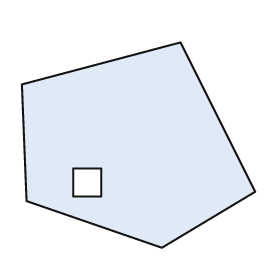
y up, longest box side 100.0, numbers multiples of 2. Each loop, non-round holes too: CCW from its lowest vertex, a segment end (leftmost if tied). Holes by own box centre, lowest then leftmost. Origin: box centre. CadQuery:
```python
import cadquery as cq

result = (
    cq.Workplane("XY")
    .moveTo(10.0, -44.0)
    .lineTo(50.0, -20.0)
    .lineTo(18.0, 44.0)
    .lineTo(-50.0, 26.0)
    .lineTo(-48.0, -24.0)
    .close()
    .moveTo(-28.0, -22.0)
    .lineTo(-16.0, -22.0)
    .lineTo(-16.0, -10.0)
    .lineTo(-28.0, -10.0)
    .close()
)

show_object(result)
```